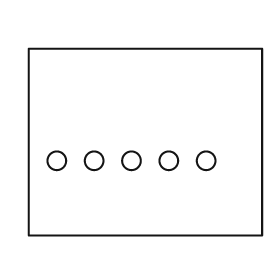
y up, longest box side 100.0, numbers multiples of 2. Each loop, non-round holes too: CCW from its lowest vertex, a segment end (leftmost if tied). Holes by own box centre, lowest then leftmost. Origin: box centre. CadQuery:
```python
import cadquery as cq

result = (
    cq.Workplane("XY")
    .moveTo(-50.0, -40.0)
    .lineTo(50.0, -40.0)
    .lineTo(50.0, 40.0)
    .lineTo(-50.0, 40.0)
    .close()
    .moveTo(-38.0, -8.0)
    .circle(4.0)
    .moveTo(-22.0, -8.0)
    .circle(4.0)
    .moveTo(-6.0, -8.0)
    .circle(4.0)
    .moveTo(10.0, -8.0)
    .circle(4.0)
    .moveTo(26.0, -8.0)
    .circle(4.0)
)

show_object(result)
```